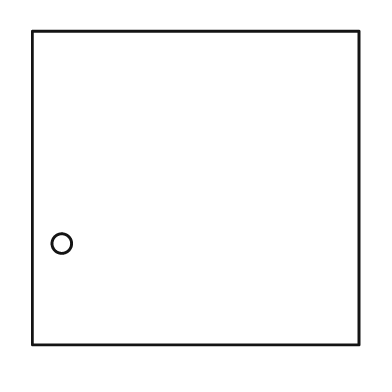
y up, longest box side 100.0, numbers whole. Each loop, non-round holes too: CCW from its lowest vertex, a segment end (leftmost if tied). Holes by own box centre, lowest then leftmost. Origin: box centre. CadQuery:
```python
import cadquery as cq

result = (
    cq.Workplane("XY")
    .moveTo(-50.0, -48.0)
    .lineTo(50.0, -48.0)
    .lineTo(50.0, 48.0)
    .lineTo(-50.0, 48.0)
    .close()
    .moveTo(-41.0, -17.0)
    .circle(3.0)
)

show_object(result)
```